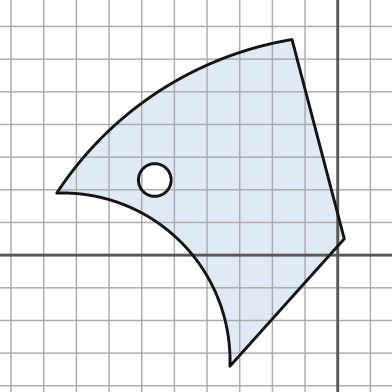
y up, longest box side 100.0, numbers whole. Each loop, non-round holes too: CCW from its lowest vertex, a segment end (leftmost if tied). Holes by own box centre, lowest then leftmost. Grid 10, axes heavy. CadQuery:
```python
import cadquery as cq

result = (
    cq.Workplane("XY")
    .moveTo(-33.0, -34.0)
    .lineTo(2.0, 5.0)
    .lineTo(-14.0, 66.0)
    .threePointArc((-55.0, 50.0), (-86.0, 19.0))
    .threePointArc((-48.0, 4.0), (-33.0, -34.0))
    .close()
    .moveTo(-56.0, 23.0)
    .circle(5.0)
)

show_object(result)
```